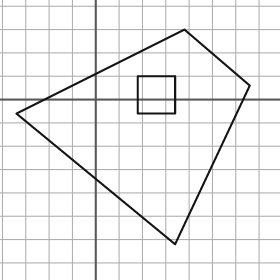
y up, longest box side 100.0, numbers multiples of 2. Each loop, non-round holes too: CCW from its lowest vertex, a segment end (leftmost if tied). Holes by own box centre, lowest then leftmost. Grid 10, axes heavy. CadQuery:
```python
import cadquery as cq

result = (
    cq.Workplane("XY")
    .moveTo(34.0, -62.0)
    .lineTo(66.0, 6.0)
    .lineTo(38.0, 30.0)
    .lineTo(-34.0, -6.0)
    .close()
    .moveTo(18.0, -6.0)
    .lineTo(34.0, -6.0)
    .lineTo(34.0, 10.0)
    .lineTo(18.0, 10.0)
    .close()
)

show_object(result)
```